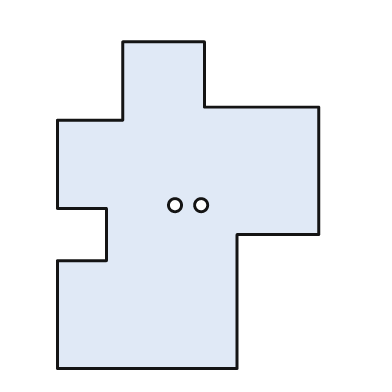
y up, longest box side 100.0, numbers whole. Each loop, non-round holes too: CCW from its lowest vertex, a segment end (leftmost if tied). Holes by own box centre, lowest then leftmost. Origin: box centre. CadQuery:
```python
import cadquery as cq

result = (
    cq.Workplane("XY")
    .moveTo(-40.0, -50.0)
    .lineTo(15.0, -50.0)
    .lineTo(15.0, -9.0)
    .lineTo(40.0, -9.0)
    .lineTo(40.0, 30.0)
    .lineTo(5.0, 30.0)
    .lineTo(5.0, 50.0)
    .lineTo(-20.0, 50.0)
    .lineTo(-20.0, 26.0)
    .lineTo(-40.0, 26.0)
    .lineTo(-40.0, -1.0)
    .lineTo(-25.0, -1.0)
    .lineTo(-25.0, -17.0)
    .lineTo(-40.0, -17.0)
    .close()
    .moveTo(-4.0, 0.0)
    .circle(2.0)
    .moveTo(4.0, 0.0)
    .circle(2.0)
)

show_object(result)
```